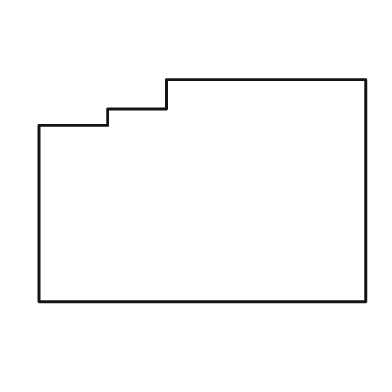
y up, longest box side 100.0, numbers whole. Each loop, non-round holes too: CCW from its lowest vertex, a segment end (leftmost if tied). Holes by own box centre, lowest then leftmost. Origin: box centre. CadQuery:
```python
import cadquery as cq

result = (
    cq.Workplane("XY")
    .moveTo(-50.0, -34.0)
    .lineTo(50.0, -34.0)
    .lineTo(50.0, 34.0)
    .lineTo(-11.0, 34.0)
    .lineTo(-11.0, 25.0)
    .lineTo(-29.0, 25.0)
    .lineTo(-29.0, 20.0)
    .lineTo(-50.0, 20.0)
    .close()
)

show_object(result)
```